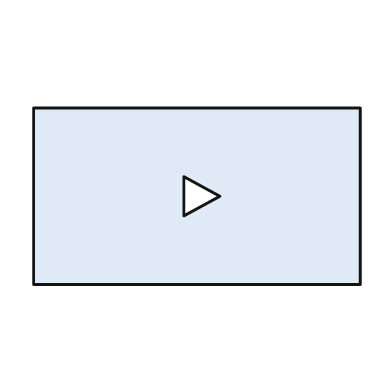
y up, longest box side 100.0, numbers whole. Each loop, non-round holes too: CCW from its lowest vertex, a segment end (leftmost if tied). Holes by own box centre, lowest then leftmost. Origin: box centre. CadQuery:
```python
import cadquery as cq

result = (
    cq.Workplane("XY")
    .moveTo(-50.0, -27.0)
    .lineTo(50.0, -27.0)
    .lineTo(50.0, 27.0)
    .lineTo(-50.0, 27.0)
    .close()
    .moveTo(-4.0, -6.0)
    .lineTo(7.0, 0.0)
    .lineTo(-4.0, 6.0)
    .close()
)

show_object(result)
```